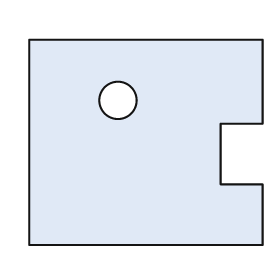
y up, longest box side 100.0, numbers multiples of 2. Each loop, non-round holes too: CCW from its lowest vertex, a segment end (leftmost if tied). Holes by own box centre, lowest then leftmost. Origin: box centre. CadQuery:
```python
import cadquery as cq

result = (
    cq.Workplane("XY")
    .moveTo(-50.0, -44.0)
    .lineTo(50.0, -44.0)
    .lineTo(50.0, -18.0)
    .lineTo(32.0, -18.0)
    .lineTo(32.0, 8.0)
    .lineTo(50.0, 8.0)
    .lineTo(50.0, 44.0)
    .lineTo(-50.0, 44.0)
    .close()
    .moveTo(-12.0, 18.0)
    .circle(8.0)
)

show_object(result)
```